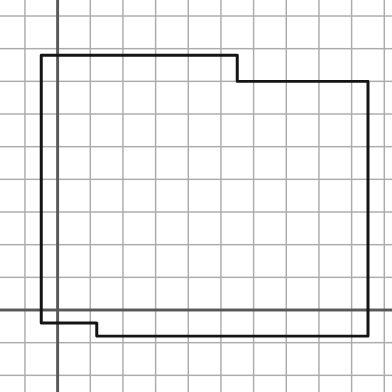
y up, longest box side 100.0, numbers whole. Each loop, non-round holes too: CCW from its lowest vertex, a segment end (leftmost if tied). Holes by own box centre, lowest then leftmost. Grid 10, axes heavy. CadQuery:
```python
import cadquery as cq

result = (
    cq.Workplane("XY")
    .moveTo(12.0, -8.0)
    .lineTo(95.0, -8.0)
    .lineTo(95.0, 70.0)
    .lineTo(55.0, 70.0)
    .lineTo(55.0, 78.0)
    .lineTo(-5.0, 78.0)
    .lineTo(-5.0, -4.0)
    .lineTo(12.0, -4.0)
    .close()
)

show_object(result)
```